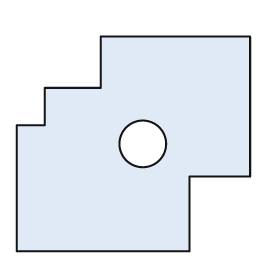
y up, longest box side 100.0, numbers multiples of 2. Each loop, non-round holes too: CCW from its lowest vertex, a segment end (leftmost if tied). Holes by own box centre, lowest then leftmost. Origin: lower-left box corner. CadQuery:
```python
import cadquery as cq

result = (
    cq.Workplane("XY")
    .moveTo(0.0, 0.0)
    .lineTo(74.0, 0.0)
    .lineTo(74.0, 32.0)
    .lineTo(100.0, 32.0)
    .lineTo(100.0, 92.0)
    .lineTo(36.0, 92.0)
    .lineTo(36.0, 70.0)
    .lineTo(12.0, 70.0)
    .lineTo(12.0, 54.0)
    .lineTo(0.0, 54.0)
    .close()
    .moveTo(54.0, 46.0)
    .circle(10.0)
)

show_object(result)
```